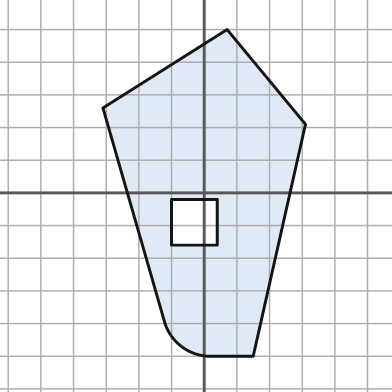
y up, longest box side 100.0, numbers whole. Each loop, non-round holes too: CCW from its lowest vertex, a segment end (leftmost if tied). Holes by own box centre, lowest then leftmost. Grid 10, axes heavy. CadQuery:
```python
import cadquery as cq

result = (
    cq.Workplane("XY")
    .moveTo(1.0, -50.0)
    .lineTo(15.0, -50.0)
    .lineTo(31.0, 21.0)
    .lineTo(7.0, 50.0)
    .lineTo(-31.0, 26.0)
    .lineTo(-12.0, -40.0)
    .threePointArc((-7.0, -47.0), (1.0, -50.0))
    .close()
    .moveTo(-10.0, -16.0)
    .lineTo(4.0, -16.0)
    .lineTo(4.0, -2.0)
    .lineTo(-10.0, -2.0)
    .close()
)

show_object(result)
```